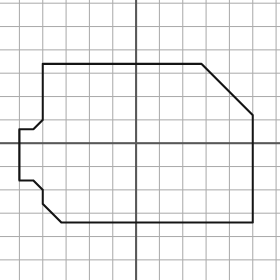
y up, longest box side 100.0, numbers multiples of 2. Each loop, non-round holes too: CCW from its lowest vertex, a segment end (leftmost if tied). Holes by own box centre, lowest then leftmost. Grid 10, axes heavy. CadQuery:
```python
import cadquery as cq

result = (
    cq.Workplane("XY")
    .moveTo(-32.0, -34.0)
    .lineTo(50.0, -34.0)
    .lineTo(50.0, 12.0)
    .lineTo(28.0, 34.0)
    .lineTo(-40.0, 34.0)
    .lineTo(-40.0, 10.0)
    .lineTo(-44.0, 6.0)
    .lineTo(-50.0, 6.0)
    .lineTo(-50.0, -16.0)
    .lineTo(-44.0, -16.0)
    .lineTo(-40.0, -20.0)
    .lineTo(-40.0, -26.0)
    .close()
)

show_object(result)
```